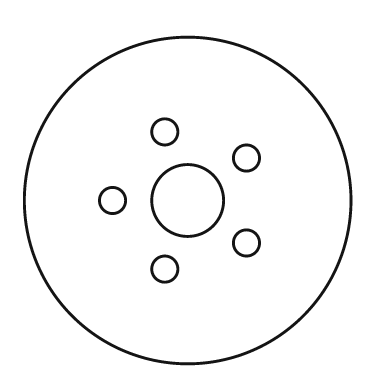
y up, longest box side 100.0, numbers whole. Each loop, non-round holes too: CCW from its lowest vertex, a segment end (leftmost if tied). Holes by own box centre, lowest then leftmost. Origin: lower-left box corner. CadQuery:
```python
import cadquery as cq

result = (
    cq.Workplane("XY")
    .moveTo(50.0, 50.0)
    .circle(50.0)
    .moveTo(43.0, 29.0)
    .circle(4.0)
    .moveTo(68.0, 37.0)
    .circle(4.0)
    .moveTo(27.0, 50.0)
    .circle(4.0)
    .moveTo(50.0, 50.0)
    .circle(11.0)
    .moveTo(68.0, 63.0)
    .circle(4.0)
    .moveTo(43.0, 71.0)
    .circle(4.0)
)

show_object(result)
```